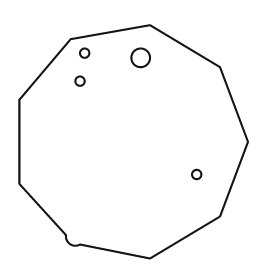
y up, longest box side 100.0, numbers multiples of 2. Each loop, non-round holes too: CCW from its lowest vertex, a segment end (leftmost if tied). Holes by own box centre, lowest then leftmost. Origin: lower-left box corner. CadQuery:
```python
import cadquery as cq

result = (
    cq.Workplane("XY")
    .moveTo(56.0, 0.0)
    .lineTo(86.0, 18.0)
    .lineTo(98.0, 50.0)
    .lineTo(86.0, 82.0)
    .lineTo(56.0, 100.0)
    .lineTo(22.0, 94.0)
    .lineTo(0.0, 68.0)
    .lineTo(0.0, 32.0)
    .lineTo(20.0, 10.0)
    .threePointArc((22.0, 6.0), (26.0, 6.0))
    .close()
    .moveTo(76.0, 36.0)
    .circle(2.0)
    .moveTo(26.0, 76.0)
    .circle(2.0)
    .moveTo(52.0, 86.0)
    .circle(4.0)
    .moveTo(28.0, 88.0)
    .circle(2.0)
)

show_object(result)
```